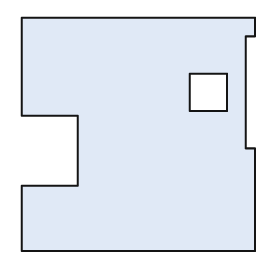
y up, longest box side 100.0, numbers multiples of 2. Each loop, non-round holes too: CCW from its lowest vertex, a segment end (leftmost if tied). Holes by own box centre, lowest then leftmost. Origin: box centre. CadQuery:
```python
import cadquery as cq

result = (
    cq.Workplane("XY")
    .moveTo(-50.0, -50.0)
    .lineTo(50.0, -50.0)
    .lineTo(50.0, -6.0)
    .lineTo(46.0, -6.0)
    .lineTo(46.0, 42.0)
    .lineTo(50.0, 42.0)
    .lineTo(50.0, 50.0)
    .lineTo(-50.0, 50.0)
    .lineTo(-50.0, 8.0)
    .lineTo(-26.0, 8.0)
    .lineTo(-26.0, -22.0)
    .lineTo(-50.0, -22.0)
    .close()
    .moveTo(22.0, 10.0)
    .lineTo(38.0, 10.0)
    .lineTo(38.0, 26.0)
    .lineTo(22.0, 26.0)
    .close()
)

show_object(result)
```